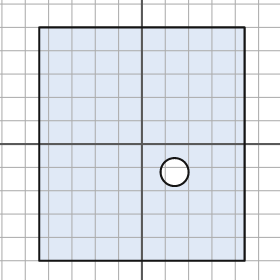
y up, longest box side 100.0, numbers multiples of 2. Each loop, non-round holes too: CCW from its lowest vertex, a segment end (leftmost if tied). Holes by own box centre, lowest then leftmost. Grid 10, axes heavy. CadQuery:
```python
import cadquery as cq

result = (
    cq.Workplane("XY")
    .moveTo(-44.0, -50.0)
    .lineTo(44.0, -50.0)
    .lineTo(44.0, 50.0)
    .lineTo(-44.0, 50.0)
    .close()
    .moveTo(14.0, -12.0)
    .circle(6.0)
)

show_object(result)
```